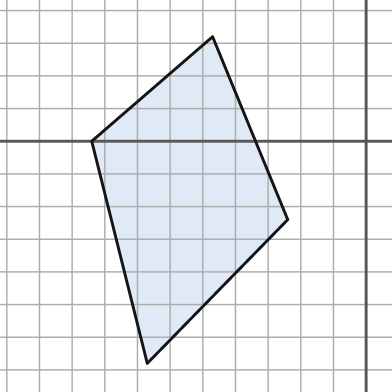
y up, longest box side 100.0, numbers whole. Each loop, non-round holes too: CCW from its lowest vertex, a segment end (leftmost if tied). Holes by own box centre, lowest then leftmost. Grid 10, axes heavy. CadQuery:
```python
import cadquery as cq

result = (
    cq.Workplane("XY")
    .moveTo(-67.0, -68.0)
    .lineTo(-24.0, -24.0)
    .lineTo(-47.0, 32.0)
    .lineTo(-84.0, 0.0)
    .close()
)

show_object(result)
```